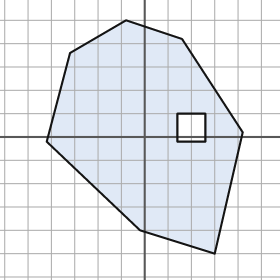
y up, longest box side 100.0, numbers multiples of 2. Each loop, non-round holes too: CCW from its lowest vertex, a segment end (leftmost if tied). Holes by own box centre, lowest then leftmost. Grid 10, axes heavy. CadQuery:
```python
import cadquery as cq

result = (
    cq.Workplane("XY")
    .moveTo(30.0, -50.0)
    .lineTo(42.0, 2.0)
    .lineTo(16.0, 42.0)
    .lineTo(-8.0, 50.0)
    .lineTo(-32.0, 36.0)
    .lineTo(-42.0, -2.0)
    .lineTo(-2.0, -40.0)
    .close()
    .moveTo(14.0, -2.0)
    .lineTo(26.0, -2.0)
    .lineTo(26.0, 10.0)
    .lineTo(14.0, 10.0)
    .close()
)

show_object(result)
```